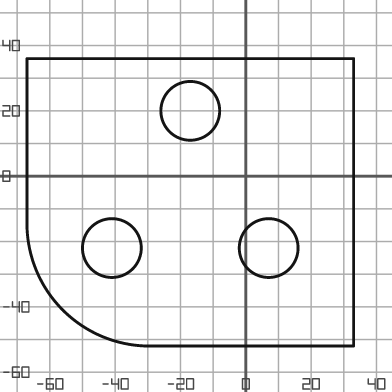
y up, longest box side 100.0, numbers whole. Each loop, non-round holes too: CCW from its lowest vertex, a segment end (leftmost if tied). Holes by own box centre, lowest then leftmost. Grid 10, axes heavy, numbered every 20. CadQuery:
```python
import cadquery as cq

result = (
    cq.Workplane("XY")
    .moveTo(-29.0, -52.0)
    .lineTo(33.0, -52.0)
    .lineTo(33.0, 36.0)
    .lineTo(-67.0, 36.0)
    .lineTo(-67.0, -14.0)
    .threePointArc((-56.0, -41.0), (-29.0, -52.0))
    .close()
    .moveTo(-41.0, -22.0)
    .circle(9.0)
    .moveTo(7.0, -22.0)
    .circle(9.0)
    .moveTo(-17.0, 20.0)
    .circle(9.0)
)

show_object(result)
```